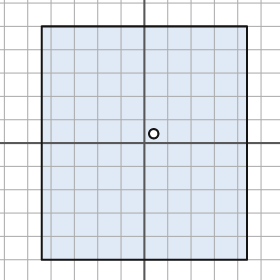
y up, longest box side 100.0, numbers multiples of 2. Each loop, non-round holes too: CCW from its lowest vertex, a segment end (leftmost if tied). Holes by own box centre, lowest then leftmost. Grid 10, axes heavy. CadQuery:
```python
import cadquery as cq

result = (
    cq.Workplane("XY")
    .moveTo(-44.0, -50.0)
    .lineTo(44.0, -50.0)
    .lineTo(44.0, 50.0)
    .lineTo(-44.0, 50.0)
    .close()
    .moveTo(4.0, 4.0)
    .circle(2.0)
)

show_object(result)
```